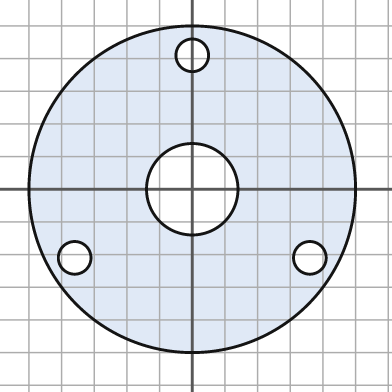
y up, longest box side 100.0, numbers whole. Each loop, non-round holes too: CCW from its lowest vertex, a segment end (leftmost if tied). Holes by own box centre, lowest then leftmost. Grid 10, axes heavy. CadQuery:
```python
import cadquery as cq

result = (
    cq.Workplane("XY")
    .moveTo(0.0, 0.0)
    .circle(50.0)
    .moveTo(-36.0, -21.0)
    .circle(5.0)
    .moveTo(36.0, -21.0)
    .circle(5.0)
    .moveTo(0.0, 0.0)
    .circle(14.0)
    .moveTo(0.0, 41.0)
    .circle(5.0)
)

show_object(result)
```